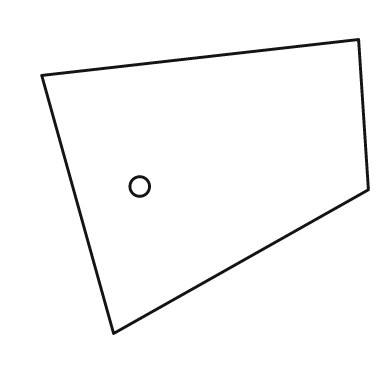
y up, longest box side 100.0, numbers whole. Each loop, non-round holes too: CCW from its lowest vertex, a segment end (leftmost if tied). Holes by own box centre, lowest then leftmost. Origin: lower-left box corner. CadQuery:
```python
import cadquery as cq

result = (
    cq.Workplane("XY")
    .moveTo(22.0, 0.0)
    .lineTo(100.0, 44.0)
    .lineTo(97.0, 90.0)
    .lineTo(0.0, 79.0)
    .close()
    .moveTo(30.0, 45.0)
    .circle(3.0)
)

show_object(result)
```